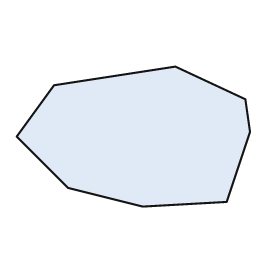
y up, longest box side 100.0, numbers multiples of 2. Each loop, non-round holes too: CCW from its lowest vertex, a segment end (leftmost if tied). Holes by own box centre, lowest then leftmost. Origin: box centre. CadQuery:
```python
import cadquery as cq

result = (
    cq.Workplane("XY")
    .moveTo(4.0, -30.0)
    .lineTo(40.0, -28.0)
    .lineTo(50.0, 2.0)
    .lineTo(48.0, 16.0)
    .lineTo(18.0, 30.0)
    .lineTo(-34.0, 22.0)
    .lineTo(-50.0, 0.0)
    .lineTo(-28.0, -22.0)
    .close()
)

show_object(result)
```